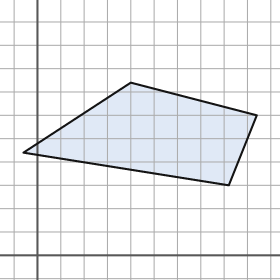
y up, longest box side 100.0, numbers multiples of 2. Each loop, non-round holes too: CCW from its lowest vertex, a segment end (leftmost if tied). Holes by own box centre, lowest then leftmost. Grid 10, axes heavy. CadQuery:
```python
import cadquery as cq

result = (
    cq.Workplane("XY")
    .moveTo(82.0, 30.0)
    .lineTo(94.0, 60.0)
    .lineTo(40.0, 74.0)
    .lineTo(-6.0, 44.0)
    .close()
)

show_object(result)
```